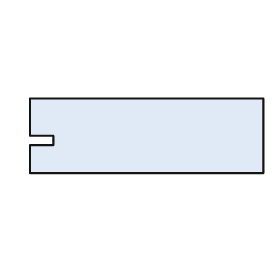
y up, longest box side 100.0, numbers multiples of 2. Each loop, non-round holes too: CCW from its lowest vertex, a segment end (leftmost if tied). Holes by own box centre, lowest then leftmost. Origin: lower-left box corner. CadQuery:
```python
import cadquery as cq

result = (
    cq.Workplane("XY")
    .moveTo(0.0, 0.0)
    .lineTo(100.0, 0.0)
    .lineTo(100.0, 32.0)
    .lineTo(0.0, 32.0)
    .lineTo(0.0, 16.0)
    .lineTo(10.0, 16.0)
    .lineTo(10.0, 12.0)
    .lineTo(0.0, 12.0)
    .close()
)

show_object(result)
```